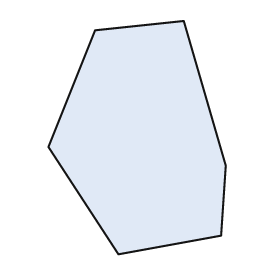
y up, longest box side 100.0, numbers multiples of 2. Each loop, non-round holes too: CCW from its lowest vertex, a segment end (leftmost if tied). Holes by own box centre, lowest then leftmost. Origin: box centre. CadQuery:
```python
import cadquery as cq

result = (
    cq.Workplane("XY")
    .moveTo(-8.0, -50.0)
    .lineTo(36.0, -42.0)
    .lineTo(38.0, -12.0)
    .lineTo(20.0, 50.0)
    .lineTo(-18.0, 46.0)
    .lineTo(-38.0, -4.0)
    .close()
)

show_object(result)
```